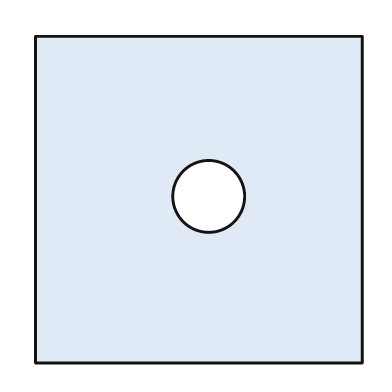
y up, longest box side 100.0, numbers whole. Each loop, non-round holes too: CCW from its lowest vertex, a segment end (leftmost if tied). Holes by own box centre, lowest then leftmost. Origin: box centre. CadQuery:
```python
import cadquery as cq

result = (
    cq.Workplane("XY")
    .moveTo(-50.0, -50.0)
    .lineTo(50.0, -50.0)
    .lineTo(50.0, 50.0)
    .lineTo(-50.0, 50.0)
    .close()
    .moveTo(3.0, 1.0)
    .circle(11.0)
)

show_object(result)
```